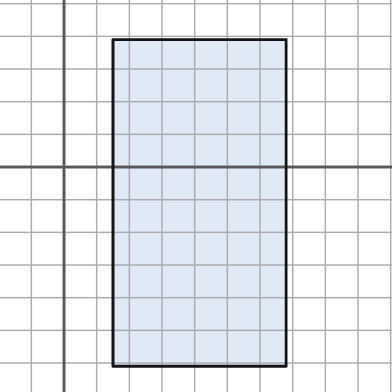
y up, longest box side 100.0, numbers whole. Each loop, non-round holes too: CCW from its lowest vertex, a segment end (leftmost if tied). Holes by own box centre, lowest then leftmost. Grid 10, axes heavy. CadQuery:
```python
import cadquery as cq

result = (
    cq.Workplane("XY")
    .moveTo(15.0, -61.0)
    .lineTo(68.0, -61.0)
    .lineTo(68.0, 39.0)
    .lineTo(15.0, 39.0)
    .close()
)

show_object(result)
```